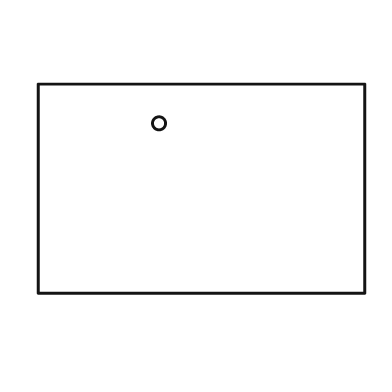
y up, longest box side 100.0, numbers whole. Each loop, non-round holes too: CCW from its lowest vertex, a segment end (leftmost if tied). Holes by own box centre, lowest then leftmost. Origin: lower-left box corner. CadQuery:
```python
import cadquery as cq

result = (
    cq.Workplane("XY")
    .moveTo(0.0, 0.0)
    .lineTo(100.0, 0.0)
    .lineTo(100.0, 64.0)
    .lineTo(0.0, 64.0)
    .close()
    .moveTo(37.0, 52.0)
    .circle(2.0)
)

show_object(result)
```